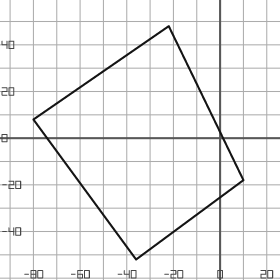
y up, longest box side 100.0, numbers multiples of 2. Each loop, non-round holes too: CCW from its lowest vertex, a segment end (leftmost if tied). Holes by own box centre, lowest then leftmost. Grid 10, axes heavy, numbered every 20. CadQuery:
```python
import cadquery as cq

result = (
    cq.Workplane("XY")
    .moveTo(-36.0, -52.0)
    .lineTo(10.0, -18.0)
    .lineTo(-22.0, 48.0)
    .lineTo(-80.0, 8.0)
    .close()
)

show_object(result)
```